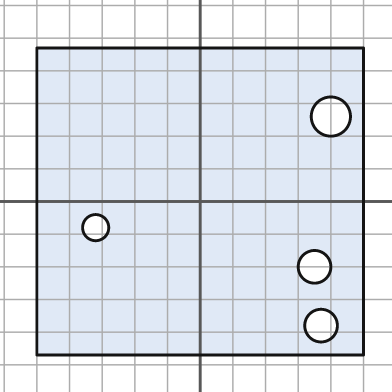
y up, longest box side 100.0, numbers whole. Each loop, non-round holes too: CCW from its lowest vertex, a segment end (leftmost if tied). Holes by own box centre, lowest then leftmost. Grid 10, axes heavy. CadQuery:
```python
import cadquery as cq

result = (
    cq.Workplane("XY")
    .moveTo(-50.0, -47.0)
    .lineTo(50.0, -47.0)
    .lineTo(50.0, 47.0)
    .lineTo(-50.0, 47.0)
    .close()
    .moveTo(37.0, -38.0)
    .circle(5.0)
    .moveTo(35.0, -20.0)
    .circle(5.0)
    .moveTo(-32.0, -8.0)
    .circle(4.0)
    .moveTo(40.0, 26.0)
    .circle(6.0)
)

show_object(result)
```